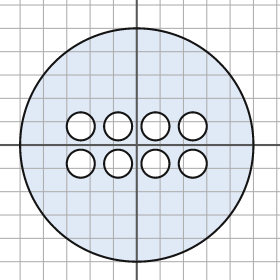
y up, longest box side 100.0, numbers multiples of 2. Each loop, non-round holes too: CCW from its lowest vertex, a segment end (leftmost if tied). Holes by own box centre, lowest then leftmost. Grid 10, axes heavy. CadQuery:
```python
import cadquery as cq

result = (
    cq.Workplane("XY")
    .moveTo(0.0, 0.0)
    .circle(50.0)
    .moveTo(-24.0, -8.0)
    .circle(6.0)
    .moveTo(-8.0, -8.0)
    .circle(6.0)
    .moveTo(8.0, -8.0)
    .circle(6.0)
    .moveTo(24.0, -8.0)
    .circle(6.0)
    .moveTo(-24.0, 8.0)
    .circle(6.0)
    .moveTo(-8.0, 8.0)
    .circle(6.0)
    .moveTo(8.0, 8.0)
    .circle(6.0)
    .moveTo(24.0, 8.0)
    .circle(6.0)
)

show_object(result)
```